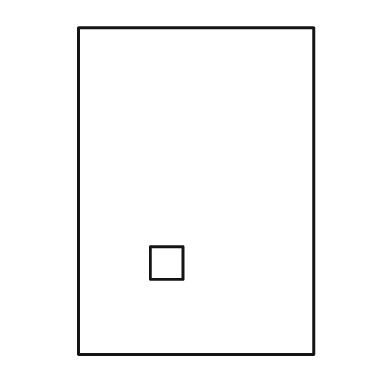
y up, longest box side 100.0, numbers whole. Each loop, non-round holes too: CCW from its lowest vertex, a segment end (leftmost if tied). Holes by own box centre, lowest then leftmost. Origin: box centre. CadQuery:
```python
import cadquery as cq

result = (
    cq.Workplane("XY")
    .moveTo(-36.0, -50.0)
    .lineTo(36.0, -50.0)
    .lineTo(36.0, 50.0)
    .lineTo(-36.0, 50.0)
    .close()
    .moveTo(-14.0, -27.0)
    .lineTo(-4.0, -27.0)
    .lineTo(-4.0, -17.0)
    .lineTo(-14.0, -17.0)
    .close()
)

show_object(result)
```